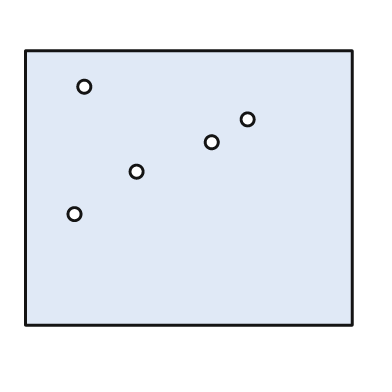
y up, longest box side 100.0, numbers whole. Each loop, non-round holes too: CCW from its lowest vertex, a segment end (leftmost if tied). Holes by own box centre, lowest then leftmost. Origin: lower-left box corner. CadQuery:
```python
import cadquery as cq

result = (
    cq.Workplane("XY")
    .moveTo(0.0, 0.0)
    .lineTo(100.0, 0.0)
    .lineTo(100.0, 84.0)
    .lineTo(0.0, 84.0)
    .close()
    .moveTo(15.0, 34.0)
    .circle(2.0)
    .moveTo(34.0, 47.0)
    .circle(2.0)
    .moveTo(57.0, 56.0)
    .circle(2.0)
    .moveTo(68.0, 63.0)
    .circle(2.0)
    .moveTo(18.0, 73.0)
    .circle(2.0)
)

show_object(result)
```